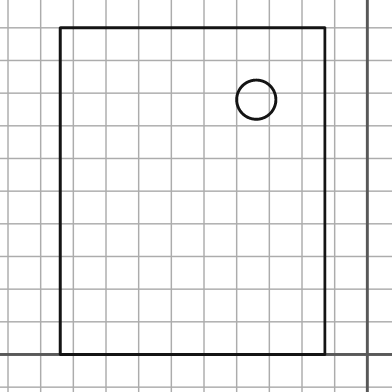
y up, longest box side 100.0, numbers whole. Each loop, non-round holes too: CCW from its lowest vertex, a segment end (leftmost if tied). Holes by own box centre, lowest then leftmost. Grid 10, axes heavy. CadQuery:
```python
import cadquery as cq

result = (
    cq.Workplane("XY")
    .moveTo(-94.0, 0.0)
    .lineTo(-13.0, 0.0)
    .lineTo(-13.0, 100.0)
    .lineTo(-94.0, 100.0)
    .close()
    .moveTo(-34.0, 78.0)
    .circle(6.0)
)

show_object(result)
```